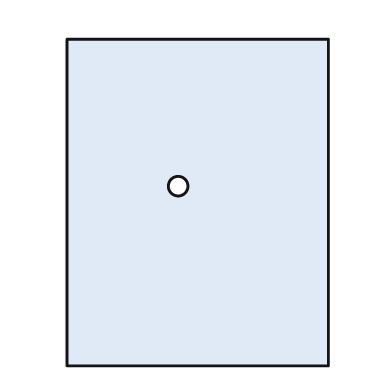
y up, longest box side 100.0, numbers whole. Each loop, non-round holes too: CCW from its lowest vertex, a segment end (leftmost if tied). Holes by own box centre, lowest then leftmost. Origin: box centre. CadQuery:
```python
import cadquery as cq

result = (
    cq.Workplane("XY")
    .moveTo(-40.0, -50.0)
    .lineTo(40.0, -50.0)
    .lineTo(40.0, 50.0)
    .lineTo(-40.0, 50.0)
    .close()
    .moveTo(-6.0, 5.0)
    .circle(3.0)
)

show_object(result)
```